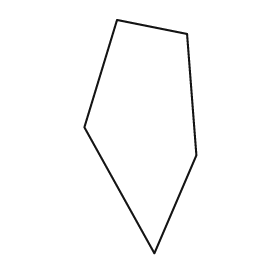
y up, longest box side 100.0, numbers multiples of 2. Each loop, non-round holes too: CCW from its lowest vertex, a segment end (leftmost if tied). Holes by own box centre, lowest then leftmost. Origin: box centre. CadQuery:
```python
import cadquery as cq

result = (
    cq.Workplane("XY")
    .moveTo(6.0, -50.0)
    .lineTo(24.0, -8.0)
    .lineTo(20.0, 44.0)
    .lineTo(-10.0, 50.0)
    .lineTo(-24.0, 4.0)
    .close()
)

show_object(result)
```